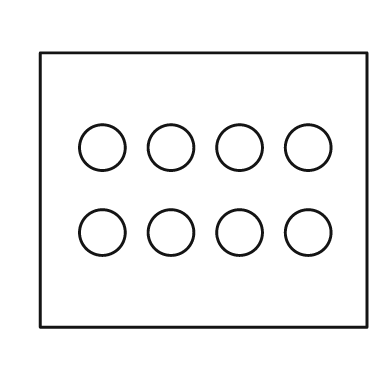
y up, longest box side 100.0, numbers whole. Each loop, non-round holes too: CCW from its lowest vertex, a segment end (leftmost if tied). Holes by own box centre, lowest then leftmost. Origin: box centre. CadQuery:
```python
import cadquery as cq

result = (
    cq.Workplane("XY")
    .moveTo(-50.0, -42.0)
    .lineTo(50.0, -42.0)
    .lineTo(50.0, 42.0)
    .lineTo(-50.0, 42.0)
    .close()
    .moveTo(-31.0, -13.0)
    .circle(7.0)
    .moveTo(-10.0, -13.0)
    .circle(7.0)
    .moveTo(11.0, -13.0)
    .circle(7.0)
    .moveTo(32.0, -13.0)
    .circle(7.0)
    .moveTo(-31.0, 13.0)
    .circle(7.0)
    .moveTo(-10.0, 13.0)
    .circle(7.0)
    .moveTo(11.0, 13.0)
    .circle(7.0)
    .moveTo(32.0, 13.0)
    .circle(7.0)
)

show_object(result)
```